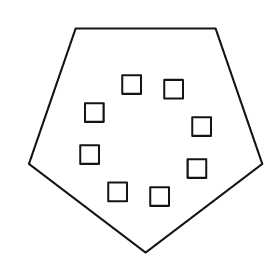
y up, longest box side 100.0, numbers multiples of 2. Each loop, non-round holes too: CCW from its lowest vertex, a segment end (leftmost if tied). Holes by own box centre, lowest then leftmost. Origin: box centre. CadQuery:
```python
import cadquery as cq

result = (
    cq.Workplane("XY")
    .moveTo(0.0, -48.0)
    .lineTo(50.0, -10.0)
    .lineTo(30.0, 48.0)
    .lineTo(-30.0, 48.0)
    .lineTo(-50.0, -10.0)
    .close()
    .moveTo(2.0, -28.0)
    .lineTo(10.0, -28.0)
    .lineTo(10.0, -20.0)
    .lineTo(2.0, -20.0)
    .close()
    .moveTo(-16.0, -26.0)
    .lineTo(-8.0, -26.0)
    .lineTo(-8.0, -18.0)
    .lineTo(-16.0, -18.0)
    .close()
    .moveTo(18.0, -16.0)
    .lineTo(26.0, -16.0)
    .lineTo(26.0, -8.0)
    .lineTo(18.0, -8.0)
    .close()
    .moveTo(-28.0, -10.0)
    .lineTo(-20.0, -10.0)
    .lineTo(-20.0, -2.0)
    .lineTo(-28.0, -2.0)
    .close()
    .moveTo(20.0, 2.0)
    .lineTo(28.0, 2.0)
    .lineTo(28.0, 10.0)
    .lineTo(20.0, 10.0)
    .close()
    .moveTo(-26.0, 8.0)
    .lineTo(-18.0, 8.0)
    .lineTo(-18.0, 16.0)
    .lineTo(-26.0, 16.0)
    .close()
    .moveTo(8.0, 18.0)
    .lineTo(16.0, 18.0)
    .lineTo(16.0, 26.0)
    .lineTo(8.0, 26.0)
    .close()
    .moveTo(-10.0, 20.0)
    .lineTo(-2.0, 20.0)
    .lineTo(-2.0, 28.0)
    .lineTo(-10.0, 28.0)
    .close()
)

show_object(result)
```